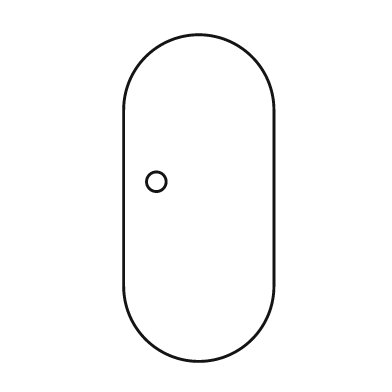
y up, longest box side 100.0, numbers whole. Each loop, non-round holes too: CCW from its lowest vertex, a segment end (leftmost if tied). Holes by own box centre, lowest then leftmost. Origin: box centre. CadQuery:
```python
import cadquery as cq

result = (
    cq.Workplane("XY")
    .moveTo(-23.0, -27.0)
    .threePointArc((0.0, -50.0), (23.0, -27.0))
    .lineTo(23.0, 27.0)
    .threePointArc((0.0, 50.0), (-23.0, 27.0))
    .close()
    .moveTo(-13.0, 5.0)
    .circle(3.0)
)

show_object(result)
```